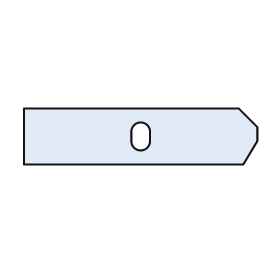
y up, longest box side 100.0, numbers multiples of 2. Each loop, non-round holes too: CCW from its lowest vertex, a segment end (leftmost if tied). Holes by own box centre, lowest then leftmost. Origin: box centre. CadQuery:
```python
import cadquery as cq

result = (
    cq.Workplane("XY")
    .moveTo(-50.0, -12.0)
    .lineTo(44.0, -12.0)
    .lineTo(50.0, -2.0)
    .lineTo(50.0, 4.0)
    .lineTo(42.0, 12.0)
    .lineTo(-50.0, 12.0)
    .close()
    .moveTo(-4.0, -2.0)
    .threePointArc((0.0, -6.0), (4.0, -2.0))
    .lineTo(4.0, 2.0)
    .threePointArc((0.0, 6.0), (-4.0, 2.0))
    .close()
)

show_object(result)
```